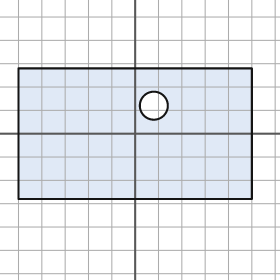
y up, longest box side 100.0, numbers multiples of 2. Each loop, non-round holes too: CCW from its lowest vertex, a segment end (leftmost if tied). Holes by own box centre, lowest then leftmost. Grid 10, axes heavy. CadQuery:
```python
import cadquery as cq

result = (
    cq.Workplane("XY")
    .moveTo(-50.0, -28.0)
    .lineTo(50.0, -28.0)
    .lineTo(50.0, 28.0)
    .lineTo(-50.0, 28.0)
    .close()
    .moveTo(8.0, 12.0)
    .circle(6.0)
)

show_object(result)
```